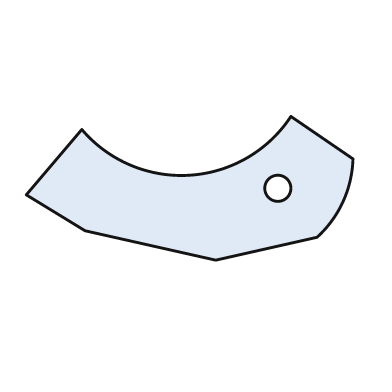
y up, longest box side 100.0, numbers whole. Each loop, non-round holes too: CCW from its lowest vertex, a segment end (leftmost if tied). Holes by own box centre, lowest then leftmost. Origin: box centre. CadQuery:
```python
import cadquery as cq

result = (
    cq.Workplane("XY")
    .moveTo(8.0, -22.0)
    .lineTo(39.0, -15.0)
    .threePointArc((47.0, -4.0), (50.0, 9.0))
    .lineTo(31.0, 22.0)
    .threePointArc((0.0, 4.0), (-33.0, 18.0))
    .lineTo(-50.0, -2.0)
    .lineTo(-32.0, -13.0)
    .close()
    .moveTo(27.0, 0.0)
    .circle(4.0)
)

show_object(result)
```